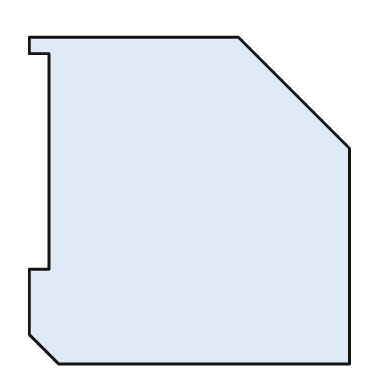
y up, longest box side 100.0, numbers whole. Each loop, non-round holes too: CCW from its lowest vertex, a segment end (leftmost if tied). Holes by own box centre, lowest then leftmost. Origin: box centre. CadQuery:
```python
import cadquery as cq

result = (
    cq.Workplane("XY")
    .moveTo(-40.0, -50.0)
    .lineTo(49.0, -50.0)
    .lineTo(49.0, 16.0)
    .lineTo(15.0, 50.0)
    .lineTo(-49.0, 50.0)
    .lineTo(-49.0, 45.0)
    .lineTo(-43.0, 45.0)
    .lineTo(-43.0, -21.0)
    .lineTo(-49.0, -21.0)
    .lineTo(-49.0, -41.0)
    .close()
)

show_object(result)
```